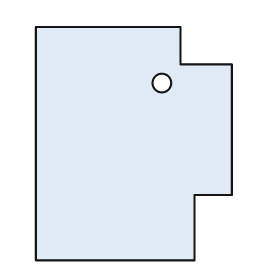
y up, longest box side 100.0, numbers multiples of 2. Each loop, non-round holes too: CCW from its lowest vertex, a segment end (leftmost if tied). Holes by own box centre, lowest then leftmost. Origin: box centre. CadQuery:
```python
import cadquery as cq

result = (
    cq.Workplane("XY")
    .moveTo(-42.0, -50.0)
    .lineTo(26.0, -50.0)
    .lineTo(26.0, -22.0)
    .lineTo(42.0, -22.0)
    .lineTo(42.0, 34.0)
    .lineTo(20.0, 34.0)
    .lineTo(20.0, 50.0)
    .lineTo(-42.0, 50.0)
    .close()
    .moveTo(12.0, 26.0)
    .circle(4.0)
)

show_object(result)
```